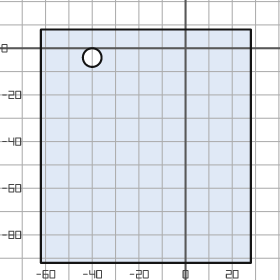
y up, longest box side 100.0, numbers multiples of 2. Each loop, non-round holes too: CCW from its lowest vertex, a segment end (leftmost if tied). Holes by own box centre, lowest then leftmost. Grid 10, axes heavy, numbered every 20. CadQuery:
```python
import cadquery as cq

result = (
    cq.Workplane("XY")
    .moveTo(-62.0, -92.0)
    .lineTo(28.0, -92.0)
    .lineTo(28.0, 8.0)
    .lineTo(-62.0, 8.0)
    .close()
    .moveTo(-40.0, -4.0)
    .circle(4.0)
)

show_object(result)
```